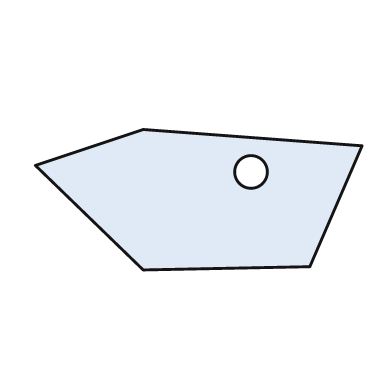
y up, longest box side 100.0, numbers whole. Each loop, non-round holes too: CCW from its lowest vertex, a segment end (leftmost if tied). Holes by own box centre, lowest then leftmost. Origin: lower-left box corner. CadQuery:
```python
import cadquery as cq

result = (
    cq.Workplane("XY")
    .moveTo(33.0, 0.0)
    .lineTo(84.0, 1.0)
    .lineTo(100.0, 38.0)
    .lineTo(33.0, 43.0)
    .lineTo(0.0, 32.0)
    .close()
    .moveTo(66.0, 30.0)
    .circle(5.0)
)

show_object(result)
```